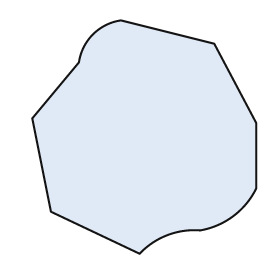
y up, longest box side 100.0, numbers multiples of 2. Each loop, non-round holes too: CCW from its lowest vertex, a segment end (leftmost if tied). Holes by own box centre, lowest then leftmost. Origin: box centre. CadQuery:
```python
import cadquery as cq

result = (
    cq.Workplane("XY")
    .moveTo(-2.0, -50.0)
    .threePointArc((10.0, -42.0), (24.0, -40.0))
    .threePointArc((38.0, -34.0), (48.0, -22.0))
    .lineTo(48.0, 6.0)
    .lineTo(30.0, 40.0)
    .lineTo(-10.0, 50.0)
    .threePointArc((-22.0, 44.0), (-28.0, 32.0))
    .lineTo(-48.0, 8.0)
    .lineTo(-40.0, -32.0)
    .close()
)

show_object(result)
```